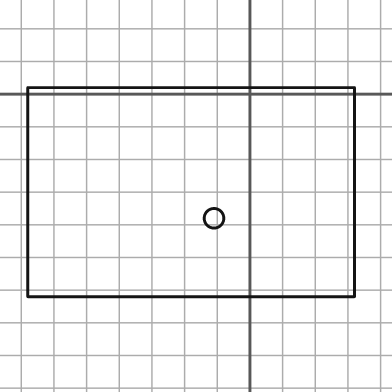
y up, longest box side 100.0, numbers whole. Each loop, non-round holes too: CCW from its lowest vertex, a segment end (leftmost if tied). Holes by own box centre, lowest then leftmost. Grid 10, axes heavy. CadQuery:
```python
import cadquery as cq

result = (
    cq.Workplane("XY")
    .moveTo(-68.0, -62.0)
    .lineTo(32.0, -62.0)
    .lineTo(32.0, 2.0)
    .lineTo(-68.0, 2.0)
    .close()
    .moveTo(-11.0, -38.0)
    .circle(3.0)
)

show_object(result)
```